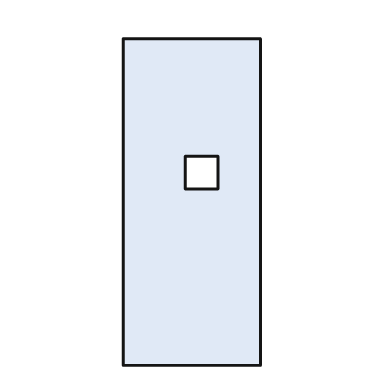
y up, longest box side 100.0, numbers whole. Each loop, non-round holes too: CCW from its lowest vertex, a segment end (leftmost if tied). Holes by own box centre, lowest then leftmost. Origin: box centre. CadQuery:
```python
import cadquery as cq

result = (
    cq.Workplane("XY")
    .moveTo(-21.0, -50.0)
    .lineTo(21.0, -50.0)
    .lineTo(21.0, 50.0)
    .lineTo(-21.0, 50.0)
    .close()
    .moveTo(-2.0, 4.0)
    .lineTo(8.0, 4.0)
    .lineTo(8.0, 14.0)
    .lineTo(-2.0, 14.0)
    .close()
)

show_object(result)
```